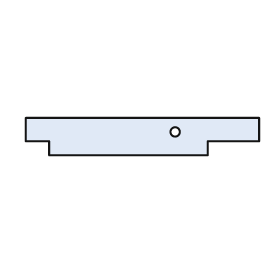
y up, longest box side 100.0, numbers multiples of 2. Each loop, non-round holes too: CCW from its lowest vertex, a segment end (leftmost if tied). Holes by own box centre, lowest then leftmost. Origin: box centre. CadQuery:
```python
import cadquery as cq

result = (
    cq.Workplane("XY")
    .moveTo(-40.0, -8.0)
    .lineTo(28.0, -8.0)
    .lineTo(28.0, -2.0)
    .lineTo(50.0, -2.0)
    .lineTo(50.0, 8.0)
    .lineTo(-50.0, 8.0)
    .lineTo(-50.0, -2.0)
    .lineTo(-40.0, -2.0)
    .close()
    .moveTo(14.0, 2.0)
    .circle(2.0)
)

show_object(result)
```